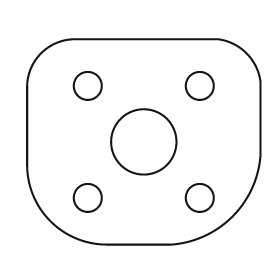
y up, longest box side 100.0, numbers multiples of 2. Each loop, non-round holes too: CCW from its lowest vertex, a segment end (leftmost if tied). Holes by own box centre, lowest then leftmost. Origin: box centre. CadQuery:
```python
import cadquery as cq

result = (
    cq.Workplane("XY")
    .moveTo(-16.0, -44.0)
    .lineTo(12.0, -44.0)
    .threePointArc((38.0, -32.0), (50.0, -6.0))
    .lineTo(50.0, 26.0)
    .threePointArc((44.0, 38.0), (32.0, 44.0))
    .lineTo(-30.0, 44.0)
    .threePointArc((-44.0, 38.0), (-50.0, 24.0))
    .lineTo(-50.0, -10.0)
    .threePointArc((-40.0, -34.0), (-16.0, -44.0))
    .close()
    .moveTo(-24.0, -24.0)
    .circle(6.0)
    .moveTo(24.0, -24.0)
    .circle(6.0)
    .moveTo(0.0, 0.0)
    .circle(14.0)
    .moveTo(-24.0, 24.0)
    .circle(6.0)
    .moveTo(24.0, 24.0)
    .circle(6.0)
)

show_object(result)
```